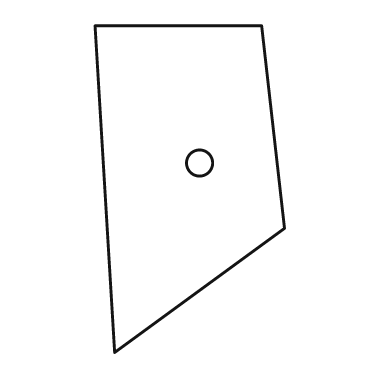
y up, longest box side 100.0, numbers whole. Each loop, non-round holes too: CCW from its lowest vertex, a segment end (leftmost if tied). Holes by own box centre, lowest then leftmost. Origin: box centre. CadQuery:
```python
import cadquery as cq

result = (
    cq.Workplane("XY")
    .moveTo(-23.0, -50.0)
    .lineTo(29.0, -12.0)
    .lineTo(22.0, 50.0)
    .lineTo(-29.0, 50.0)
    .close()
    .moveTo(3.0, 8.0)
    .circle(4.0)
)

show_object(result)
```